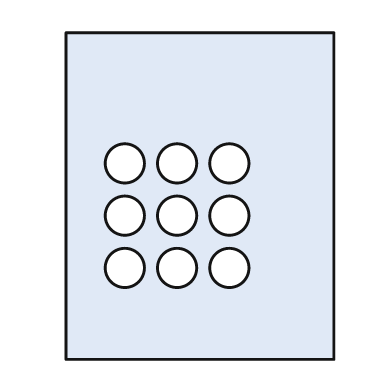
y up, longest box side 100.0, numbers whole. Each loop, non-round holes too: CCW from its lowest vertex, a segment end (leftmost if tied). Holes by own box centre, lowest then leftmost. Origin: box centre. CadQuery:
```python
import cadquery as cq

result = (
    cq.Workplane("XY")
    .moveTo(-41.0, -50.0)
    .lineTo(41.0, -50.0)
    .lineTo(41.0, 50.0)
    .lineTo(-41.0, 50.0)
    .close()
    .moveTo(-23.0, -22.0)
    .circle(6.0)
    .moveTo(-7.0, -22.0)
    .circle(6.0)
    .moveTo(9.0, -22.0)
    .circle(6.0)
    .moveTo(-23.0, -6.0)
    .circle(6.0)
    .moveTo(-7.0, -6.0)
    .circle(6.0)
    .moveTo(9.0, -6.0)
    .circle(6.0)
    .moveTo(-23.0, 10.0)
    .circle(6.0)
    .moveTo(-7.0, 10.0)
    .circle(6.0)
    .moveTo(9.0, 10.0)
    .circle(6.0)
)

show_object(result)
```